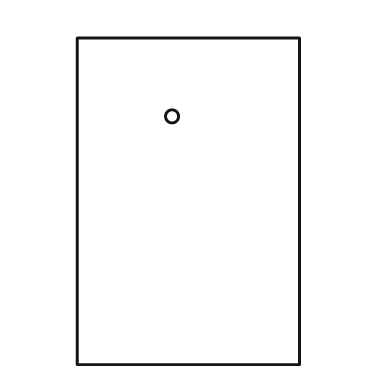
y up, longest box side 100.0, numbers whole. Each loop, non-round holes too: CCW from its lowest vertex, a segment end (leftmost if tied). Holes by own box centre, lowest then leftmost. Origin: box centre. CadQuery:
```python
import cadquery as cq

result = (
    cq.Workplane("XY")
    .moveTo(-34.0, -50.0)
    .lineTo(34.0, -50.0)
    .lineTo(34.0, 50.0)
    .lineTo(-34.0, 50.0)
    .close()
    .moveTo(-5.0, 26.0)
    .circle(2.0)
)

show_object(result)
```